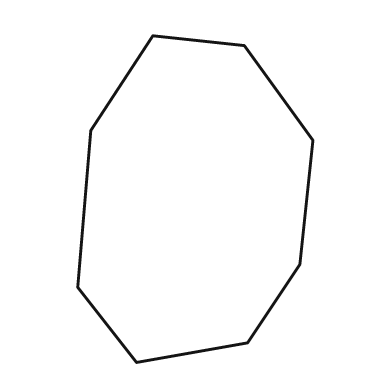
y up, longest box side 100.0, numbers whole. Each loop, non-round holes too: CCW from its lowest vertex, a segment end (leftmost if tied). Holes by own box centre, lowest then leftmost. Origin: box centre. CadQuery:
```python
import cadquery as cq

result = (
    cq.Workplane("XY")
    .moveTo(-18.0, -50.0)
    .lineTo(16.0, -44.0)
    .lineTo(32.0, -20.0)
    .lineTo(36.0, 18.0)
    .lineTo(15.0, 47.0)
    .lineTo(-13.0, 50.0)
    .lineTo(-32.0, 21.0)
    .lineTo(-36.0, -27.0)
    .close()
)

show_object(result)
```